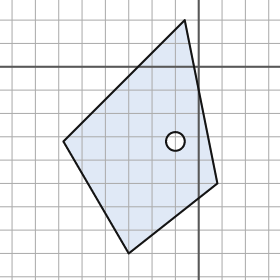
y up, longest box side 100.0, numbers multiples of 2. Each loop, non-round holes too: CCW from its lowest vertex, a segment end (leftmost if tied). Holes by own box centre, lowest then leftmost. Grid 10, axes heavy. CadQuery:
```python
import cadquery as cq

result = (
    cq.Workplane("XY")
    .moveTo(-30.0, -80.0)
    .lineTo(8.0, -50.0)
    .lineTo(-6.0, 20.0)
    .lineTo(-58.0, -32.0)
    .close()
    .moveTo(-10.0, -32.0)
    .circle(4.0)
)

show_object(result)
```